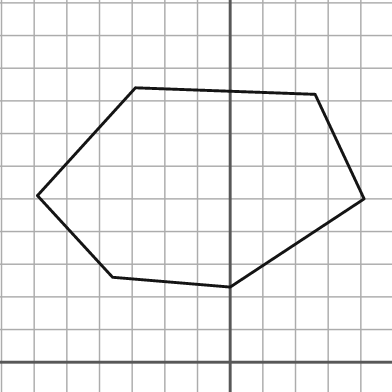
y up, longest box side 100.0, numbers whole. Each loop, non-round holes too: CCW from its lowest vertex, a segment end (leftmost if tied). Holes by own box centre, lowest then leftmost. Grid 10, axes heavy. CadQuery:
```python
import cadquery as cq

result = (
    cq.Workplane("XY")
    .moveTo(0.0, 23.0)
    .lineTo(41.0, 50.0)
    .lineTo(26.0, 82.0)
    .lineTo(-29.0, 84.0)
    .lineTo(-59.0, 51.0)
    .lineTo(-36.0, 26.0)
    .close()
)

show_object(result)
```